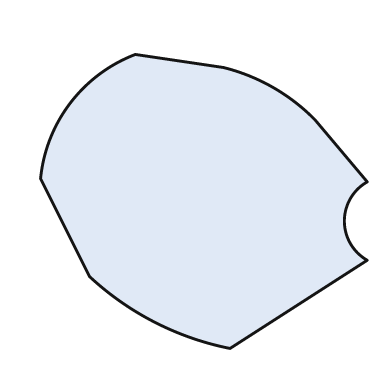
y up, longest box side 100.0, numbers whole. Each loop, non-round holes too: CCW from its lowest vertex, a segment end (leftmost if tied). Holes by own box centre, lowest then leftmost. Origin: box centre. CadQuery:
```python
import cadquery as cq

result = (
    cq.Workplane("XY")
    .moveTo(8.0, -45.0)
    .lineTo(50.0, -18.0)
    .threePointArc((43.0, -6.0), (50.0, 6.0))
    .lineTo(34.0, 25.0)
    .threePointArc((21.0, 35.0), (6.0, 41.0))
    .lineTo(-21.0, 45.0)
    .threePointArc((-41.0, 30.0), (-50.0, 7.0))
    .lineTo(-35.0, -23.0)
    .threePointArc((-15.0, -37.0), (8.0, -45.0))
    .close()
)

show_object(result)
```